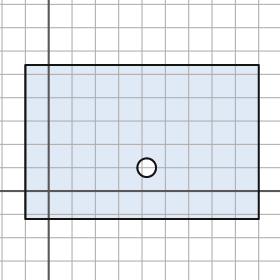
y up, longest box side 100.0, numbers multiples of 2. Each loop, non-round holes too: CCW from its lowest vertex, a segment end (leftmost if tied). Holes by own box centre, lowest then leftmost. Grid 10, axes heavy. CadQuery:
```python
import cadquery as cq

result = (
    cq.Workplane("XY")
    .moveTo(-10.0, -12.0)
    .lineTo(90.0, -12.0)
    .lineTo(90.0, 54.0)
    .lineTo(-10.0, 54.0)
    .close()
    .moveTo(42.0, 10.0)
    .circle(4.0)
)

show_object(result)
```